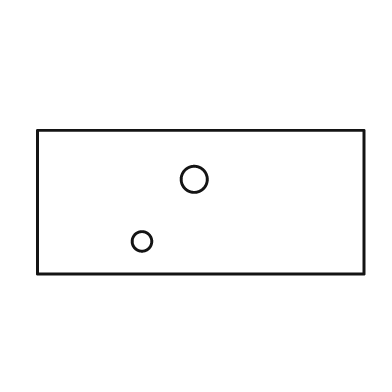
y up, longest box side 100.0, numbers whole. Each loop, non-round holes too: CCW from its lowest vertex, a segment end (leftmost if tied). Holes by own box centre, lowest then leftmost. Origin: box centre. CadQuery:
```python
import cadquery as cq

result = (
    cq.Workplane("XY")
    .moveTo(-50.0, -22.0)
    .lineTo(50.0, -22.0)
    .lineTo(50.0, 22.0)
    .lineTo(-50.0, 22.0)
    .close()
    .moveTo(-18.0, -12.0)
    .circle(3.0)
    .moveTo(-2.0, 7.0)
    .circle(4.0)
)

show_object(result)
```